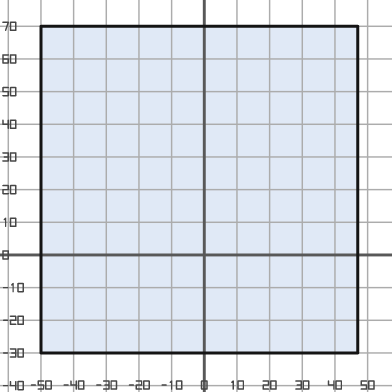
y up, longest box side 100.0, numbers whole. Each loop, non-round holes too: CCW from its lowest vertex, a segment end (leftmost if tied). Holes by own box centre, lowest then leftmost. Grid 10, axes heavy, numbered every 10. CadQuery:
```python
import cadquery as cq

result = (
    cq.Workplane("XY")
    .moveTo(-50.0, -30.0)
    .lineTo(47.0, -30.0)
    .lineTo(47.0, 70.0)
    .lineTo(-50.0, 70.0)
    .close()
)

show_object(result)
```